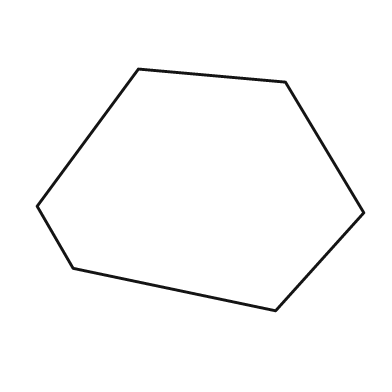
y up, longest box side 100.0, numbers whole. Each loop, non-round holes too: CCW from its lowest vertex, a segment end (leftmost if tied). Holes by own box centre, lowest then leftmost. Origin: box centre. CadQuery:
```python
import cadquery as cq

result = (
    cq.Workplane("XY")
    .moveTo(23.0, -37.0)
    .lineTo(50.0, -7.0)
    .lineTo(26.0, 33.0)
    .lineTo(-19.0, 37.0)
    .lineTo(-50.0, -5.0)
    .lineTo(-39.0, -24.0)
    .close()
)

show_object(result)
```